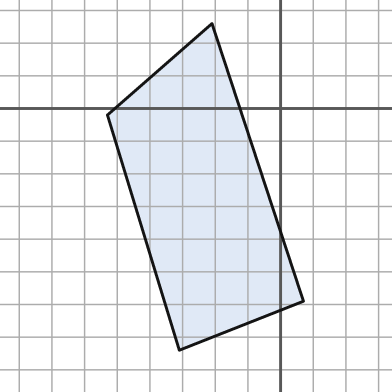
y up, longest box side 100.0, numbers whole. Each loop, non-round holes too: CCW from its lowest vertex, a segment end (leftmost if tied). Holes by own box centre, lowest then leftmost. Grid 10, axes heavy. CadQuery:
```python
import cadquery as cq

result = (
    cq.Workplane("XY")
    .moveTo(-31.0, -74.0)
    .lineTo(7.0, -59.0)
    .lineTo(-21.0, 26.0)
    .lineTo(-53.0, -2.0)
    .close()
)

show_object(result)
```